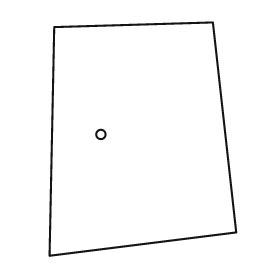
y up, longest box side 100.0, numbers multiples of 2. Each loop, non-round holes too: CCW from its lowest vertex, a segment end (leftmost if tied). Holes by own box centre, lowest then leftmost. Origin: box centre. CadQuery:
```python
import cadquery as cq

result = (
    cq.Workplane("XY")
    .moveTo(-40.0, -50.0)
    .lineTo(40.0, -40.0)
    .lineTo(30.0, 50.0)
    .lineTo(-38.0, 48.0)
    .close()
    .moveTo(-18.0, 2.0)
    .circle(2.0)
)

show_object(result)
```